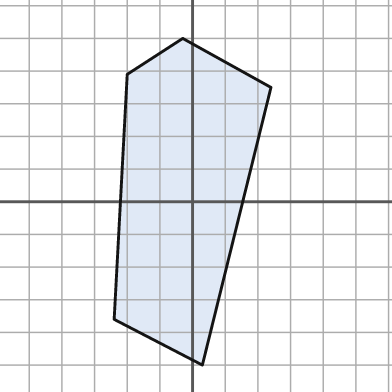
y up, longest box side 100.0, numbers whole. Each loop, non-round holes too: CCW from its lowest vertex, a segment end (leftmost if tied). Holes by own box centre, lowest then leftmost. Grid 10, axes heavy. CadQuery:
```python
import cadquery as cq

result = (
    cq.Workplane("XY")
    .moveTo(3.0, -50.0)
    .lineTo(24.0, 35.0)
    .lineTo(-3.0, 50.0)
    .lineTo(-20.0, 39.0)
    .lineTo(-24.0, -36.0)
    .close()
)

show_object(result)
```